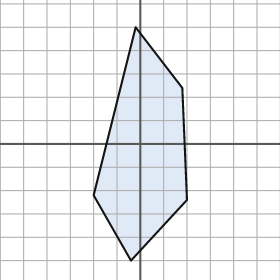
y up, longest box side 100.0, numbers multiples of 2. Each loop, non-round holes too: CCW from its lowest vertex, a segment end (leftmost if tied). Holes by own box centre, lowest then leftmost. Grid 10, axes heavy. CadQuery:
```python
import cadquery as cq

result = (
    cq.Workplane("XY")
    .moveTo(-4.0, -50.0)
    .lineTo(20.0, -24.0)
    .lineTo(18.0, 24.0)
    .lineTo(-2.0, 50.0)
    .lineTo(-20.0, -22.0)
    .close()
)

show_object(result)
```